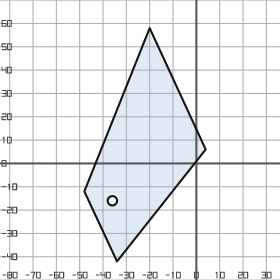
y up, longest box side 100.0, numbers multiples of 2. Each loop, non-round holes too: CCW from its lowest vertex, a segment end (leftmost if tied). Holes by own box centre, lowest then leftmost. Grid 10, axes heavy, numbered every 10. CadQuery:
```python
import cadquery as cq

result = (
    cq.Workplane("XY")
    .moveTo(-34.0, -42.0)
    .lineTo(4.0, 6.0)
    .lineTo(-20.0, 58.0)
    .lineTo(-48.0, -12.0)
    .close()
    .moveTo(-36.0, -16.0)
    .circle(2.0)
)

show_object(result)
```